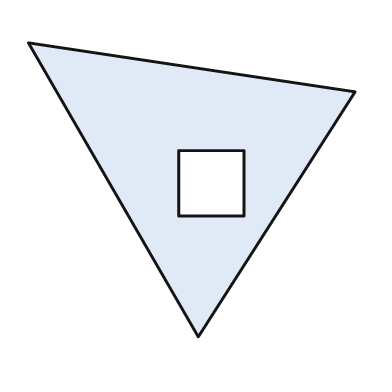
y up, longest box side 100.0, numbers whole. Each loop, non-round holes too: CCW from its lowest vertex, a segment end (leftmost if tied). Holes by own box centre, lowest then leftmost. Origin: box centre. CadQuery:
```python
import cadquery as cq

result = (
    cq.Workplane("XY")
    .moveTo(2.0, -45.0)
    .lineTo(50.0, 30.0)
    .lineTo(-50.0, 45.0)
    .close()
    .moveTo(-4.0, -8.0)
    .lineTo(16.0, -8.0)
    .lineTo(16.0, 12.0)
    .lineTo(-4.0, 12.0)
    .close()
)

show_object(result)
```